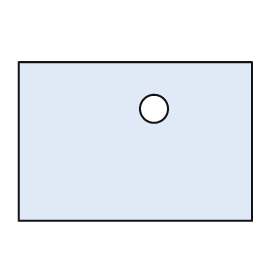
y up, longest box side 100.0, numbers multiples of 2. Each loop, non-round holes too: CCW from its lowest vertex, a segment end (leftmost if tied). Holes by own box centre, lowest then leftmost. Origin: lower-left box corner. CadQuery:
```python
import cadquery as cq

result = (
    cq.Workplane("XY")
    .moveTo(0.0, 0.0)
    .lineTo(100.0, 0.0)
    .lineTo(100.0, 68.0)
    .lineTo(0.0, 68.0)
    .close()
    .moveTo(58.0, 48.0)
    .circle(6.0)
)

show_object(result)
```